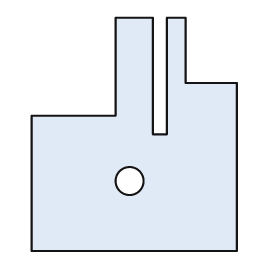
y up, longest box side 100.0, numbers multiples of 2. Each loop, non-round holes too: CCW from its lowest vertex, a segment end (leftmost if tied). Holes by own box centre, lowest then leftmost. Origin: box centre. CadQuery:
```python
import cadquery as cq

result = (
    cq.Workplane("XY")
    .moveTo(-44.0, -50.0)
    .lineTo(44.0, -50.0)
    .lineTo(44.0, 22.0)
    .lineTo(22.0, 22.0)
    .lineTo(22.0, 50.0)
    .lineTo(14.0, 50.0)
    .lineTo(14.0, 0.0)
    .lineTo(8.0, 0.0)
    .lineTo(8.0, 50.0)
    .lineTo(-8.0, 50.0)
    .lineTo(-8.0, 8.0)
    .lineTo(-44.0, 8.0)
    .close()
    .moveTo(-2.0, -20.0)
    .circle(6.0)
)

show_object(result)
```